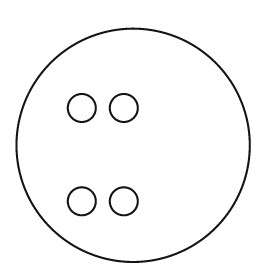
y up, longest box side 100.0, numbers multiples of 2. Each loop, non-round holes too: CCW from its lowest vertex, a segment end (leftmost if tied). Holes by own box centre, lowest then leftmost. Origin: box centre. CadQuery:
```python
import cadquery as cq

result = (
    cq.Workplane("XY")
    .moveTo(0.0, 0.0)
    .circle(50.0)
    .moveTo(-22.0, -24.0)
    .circle(6.0)
    .moveTo(-4.0, -24.0)
    .circle(6.0)
    .moveTo(-22.0, 16.0)
    .circle(6.0)
    .moveTo(-4.0, 16.0)
    .circle(6.0)
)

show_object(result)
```